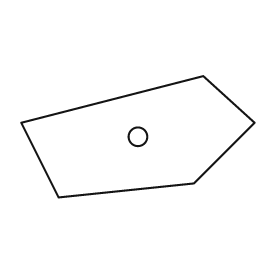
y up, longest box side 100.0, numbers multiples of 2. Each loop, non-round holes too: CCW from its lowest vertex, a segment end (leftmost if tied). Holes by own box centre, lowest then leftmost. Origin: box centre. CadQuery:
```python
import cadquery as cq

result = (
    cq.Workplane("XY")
    .moveTo(-34.0, -26.0)
    .lineTo(24.0, -20.0)
    .lineTo(50.0, 6.0)
    .lineTo(28.0, 26.0)
    .lineTo(-50.0, 6.0)
    .close()
    .moveTo(0.0, 0.0)
    .circle(4.0)
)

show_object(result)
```